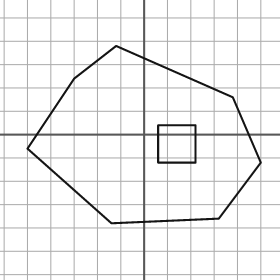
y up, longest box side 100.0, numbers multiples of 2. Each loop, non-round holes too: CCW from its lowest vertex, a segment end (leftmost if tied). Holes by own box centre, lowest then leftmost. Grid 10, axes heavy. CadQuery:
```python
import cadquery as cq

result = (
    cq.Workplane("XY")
    .moveTo(-14.0, -38.0)
    .lineTo(32.0, -36.0)
    .lineTo(50.0, -12.0)
    .lineTo(38.0, 16.0)
    .lineTo(-12.0, 38.0)
    .lineTo(-30.0, 24.0)
    .lineTo(-50.0, -6.0)
    .close()
    .moveTo(6.0, -12.0)
    .lineTo(22.0, -12.0)
    .lineTo(22.0, 4.0)
    .lineTo(6.0, 4.0)
    .close()
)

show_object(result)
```